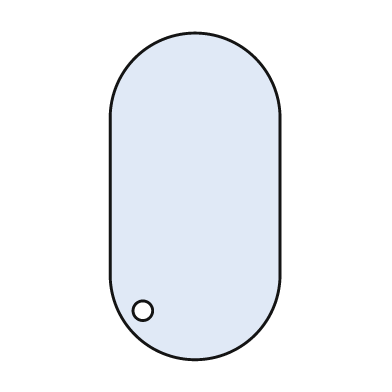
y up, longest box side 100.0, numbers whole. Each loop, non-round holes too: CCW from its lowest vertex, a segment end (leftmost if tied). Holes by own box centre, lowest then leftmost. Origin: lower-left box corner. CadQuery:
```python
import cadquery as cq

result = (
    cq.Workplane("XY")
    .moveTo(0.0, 26.0)
    .threePointArc((26.0, 0.0), (52.0, 26.0))
    .lineTo(52.0, 74.0)
    .threePointArc((26.0, 100.0), (0.0, 74.0))
    .close()
    .moveTo(10.0, 15.0)
    .circle(3.0)
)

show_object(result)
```